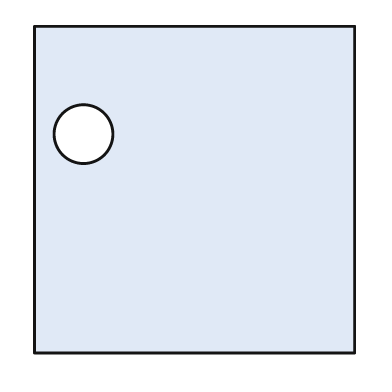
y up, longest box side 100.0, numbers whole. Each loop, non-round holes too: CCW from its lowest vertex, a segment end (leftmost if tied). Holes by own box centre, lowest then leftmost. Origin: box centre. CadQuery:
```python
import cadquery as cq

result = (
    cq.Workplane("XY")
    .moveTo(-49.0, -50.0)
    .lineTo(49.0, -50.0)
    .lineTo(49.0, 50.0)
    .lineTo(-49.0, 50.0)
    .close()
    .moveTo(-34.0, 17.0)
    .circle(9.0)
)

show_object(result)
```